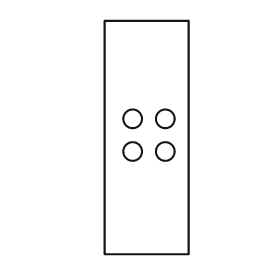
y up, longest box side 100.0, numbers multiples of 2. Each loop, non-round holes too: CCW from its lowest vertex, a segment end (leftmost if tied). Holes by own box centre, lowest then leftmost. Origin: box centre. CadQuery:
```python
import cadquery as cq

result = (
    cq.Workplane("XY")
    .moveTo(-18.0, -50.0)
    .lineTo(18.0, -50.0)
    .lineTo(18.0, 50.0)
    .lineTo(-18.0, 50.0)
    .close()
    .moveTo(-6.0, -6.0)
    .circle(4.0)
    .moveTo(8.0, -6.0)
    .circle(4.0)
    .moveTo(-6.0, 8.0)
    .circle(4.0)
    .moveTo(8.0, 8.0)
    .circle(4.0)
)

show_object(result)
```